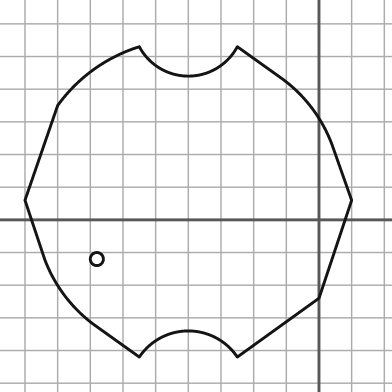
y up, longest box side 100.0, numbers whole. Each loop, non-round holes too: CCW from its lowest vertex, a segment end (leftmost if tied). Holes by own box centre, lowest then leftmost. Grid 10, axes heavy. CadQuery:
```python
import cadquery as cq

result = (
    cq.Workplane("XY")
    .moveTo(-55.0, -42.0)
    .threePointArc((-40.0, -34.0), (-25.0, -42.0))
    .lineTo(0.0, -24.0)
    .lineTo(10.0, 6.0)
    .lineTo(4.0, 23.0)
    .threePointArc((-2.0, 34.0), (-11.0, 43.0))
    .lineTo(-25.0, 53.0)
    .threePointArc((-40.0, 44.0), (-55.0, 53.0))
    .threePointArc((-69.0, 46.0), (-80.0, 35.0))
    .lineTo(-90.0, 6.0)
    .lineTo(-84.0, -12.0)
    .threePointArc((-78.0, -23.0), (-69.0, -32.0))
    .close()
    .moveTo(-68.0, -12.0)
    .circle(2.0)
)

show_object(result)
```